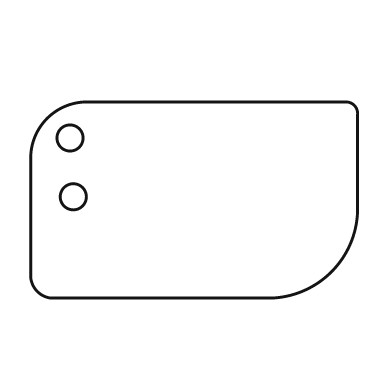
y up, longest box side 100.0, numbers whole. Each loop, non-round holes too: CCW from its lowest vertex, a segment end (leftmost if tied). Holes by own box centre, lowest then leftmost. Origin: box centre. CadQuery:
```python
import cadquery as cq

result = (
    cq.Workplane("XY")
    .moveTo(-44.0, -30.0)
    .lineTo(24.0, -30.0)
    .threePointArc((42.0, -22.0), (50.0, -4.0))
    .lineTo(50.0, 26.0)
    .threePointArc((49.0, 29.0), (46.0, 30.0))
    .lineTo(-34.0, 30.0)
    .threePointArc((-45.0, 25.0), (-50.0, 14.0))
    .lineTo(-50.0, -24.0)
    .threePointArc((-48.0, -28.0), (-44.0, -30.0))
    .close()
    .moveTo(-37.0, 1.0)
    .circle(4.0)
    .moveTo(-38.0, 19.0)
    .circle(4.0)
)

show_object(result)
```